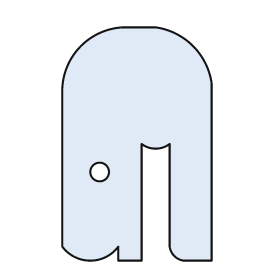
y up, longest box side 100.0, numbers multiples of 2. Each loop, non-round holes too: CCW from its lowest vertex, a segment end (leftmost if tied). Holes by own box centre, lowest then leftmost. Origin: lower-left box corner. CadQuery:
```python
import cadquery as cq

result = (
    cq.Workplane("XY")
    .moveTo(24.0, 0.0)
    .lineTo(34.0, 0.0)
    .lineTo(34.0, 50.0)
    .threePointArc((40.0, 48.0), (46.0, 50.0))
    .lineTo(46.0, 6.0)
    .threePointArc((48.0, 2.0), (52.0, 0.0))
    .lineTo(64.0, 0.0)
    .lineTo(64.0, 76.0)
    .threePointArc((56.0, 92.0), (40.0, 100.0))
    .lineTo(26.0, 100.0)
    .threePointArc((8.0, 92.0), (0.0, 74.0))
    .lineTo(0.0, 6.0)
    .threePointArc((12.0, 0.0), (24.0, 6.0))
    .close()
    .moveTo(16.0, 38.0)
    .circle(4.0)
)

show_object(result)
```